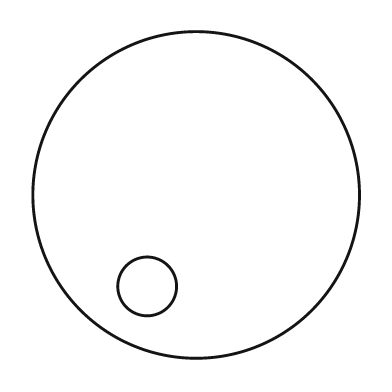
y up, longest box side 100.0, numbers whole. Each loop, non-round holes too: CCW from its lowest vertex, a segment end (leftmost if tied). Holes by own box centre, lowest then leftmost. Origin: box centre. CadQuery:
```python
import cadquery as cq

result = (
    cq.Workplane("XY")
    .moveTo(0.0, 0.0)
    .circle(50.0)
    .moveTo(-15.0, -28.0)
    .circle(9.0)
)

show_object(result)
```